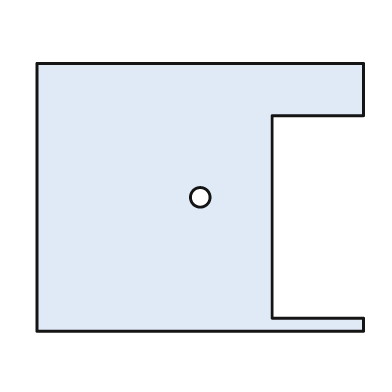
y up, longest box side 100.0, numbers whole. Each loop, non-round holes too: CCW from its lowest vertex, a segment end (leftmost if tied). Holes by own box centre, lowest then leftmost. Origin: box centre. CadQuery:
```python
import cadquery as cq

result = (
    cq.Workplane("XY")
    .moveTo(-50.0, -41.0)
    .lineTo(50.0, -41.0)
    .lineTo(50.0, -37.0)
    .lineTo(22.0, -37.0)
    .lineTo(22.0, 25.0)
    .lineTo(50.0, 25.0)
    .lineTo(50.0, 41.0)
    .lineTo(-50.0, 41.0)
    .close()
    .moveTo(0.0, 0.0)
    .circle(3.0)
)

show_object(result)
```